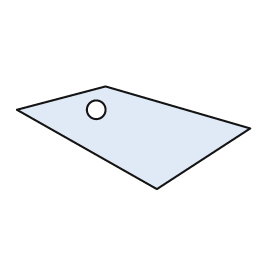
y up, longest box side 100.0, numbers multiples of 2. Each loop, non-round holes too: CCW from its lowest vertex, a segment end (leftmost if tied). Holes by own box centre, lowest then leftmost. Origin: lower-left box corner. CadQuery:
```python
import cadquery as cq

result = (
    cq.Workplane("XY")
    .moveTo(60.0, 0.0)
    .lineTo(100.0, 26.0)
    .lineTo(38.0, 44.0)
    .lineTo(0.0, 34.0)
    .close()
    .moveTo(34.0, 34.0)
    .circle(4.0)
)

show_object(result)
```